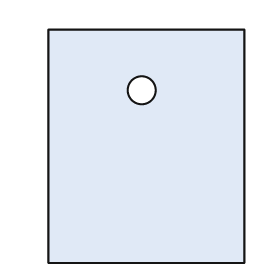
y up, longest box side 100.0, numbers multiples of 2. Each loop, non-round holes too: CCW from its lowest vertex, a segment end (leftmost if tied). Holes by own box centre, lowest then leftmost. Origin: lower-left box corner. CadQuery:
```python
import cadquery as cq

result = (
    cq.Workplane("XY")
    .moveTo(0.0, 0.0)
    .lineTo(84.0, 0.0)
    .lineTo(84.0, 100.0)
    .lineTo(0.0, 100.0)
    .close()
    .moveTo(40.0, 74.0)
    .circle(6.0)
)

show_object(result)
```